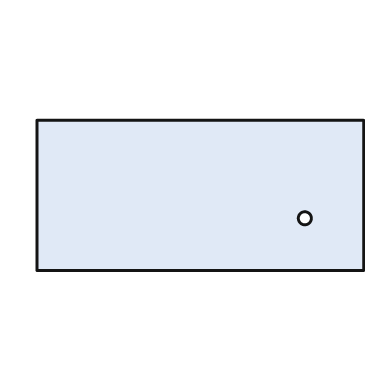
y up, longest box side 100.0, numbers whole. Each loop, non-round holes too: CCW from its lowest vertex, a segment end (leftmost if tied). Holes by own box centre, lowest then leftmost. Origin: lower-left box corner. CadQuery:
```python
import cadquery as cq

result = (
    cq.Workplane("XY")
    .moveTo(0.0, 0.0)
    .lineTo(100.0, 0.0)
    .lineTo(100.0, 46.0)
    .lineTo(0.0, 46.0)
    .close()
    .moveTo(82.0, 16.0)
    .circle(2.0)
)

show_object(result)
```